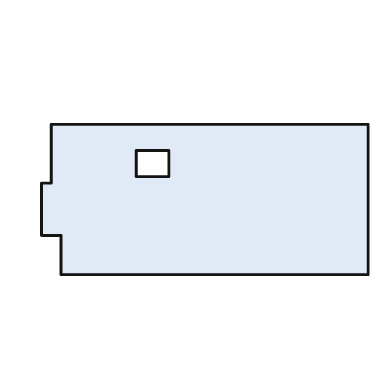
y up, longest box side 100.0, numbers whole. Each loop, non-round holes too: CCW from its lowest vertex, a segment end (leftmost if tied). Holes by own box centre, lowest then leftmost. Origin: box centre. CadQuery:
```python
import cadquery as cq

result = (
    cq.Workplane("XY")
    .moveTo(-44.0, -23.0)
    .lineTo(50.0, -23.0)
    .lineTo(50.0, 23.0)
    .lineTo(-47.0, 23.0)
    .lineTo(-47.0, 5.0)
    .lineTo(-50.0, 5.0)
    .lineTo(-50.0, -11.0)
    .lineTo(-44.0, -11.0)
    .close()
    .moveTo(-21.0, 7.0)
    .lineTo(-11.0, 7.0)
    .lineTo(-11.0, 15.0)
    .lineTo(-21.0, 15.0)
    .close()
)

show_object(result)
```